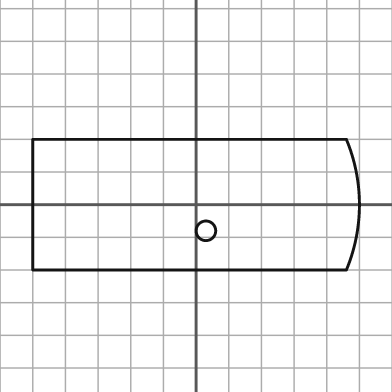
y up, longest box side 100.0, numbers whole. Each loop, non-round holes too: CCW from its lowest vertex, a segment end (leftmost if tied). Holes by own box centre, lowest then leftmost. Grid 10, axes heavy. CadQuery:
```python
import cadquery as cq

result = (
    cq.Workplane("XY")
    .moveTo(-50.0, -20.0)
    .lineTo(46.0, -20.0)
    .threePointArc((50.0, 0.0), (46.0, 20.0))
    .lineTo(-50.0, 20.0)
    .close()
    .moveTo(3.0, -8.0)
    .circle(3.0)
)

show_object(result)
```